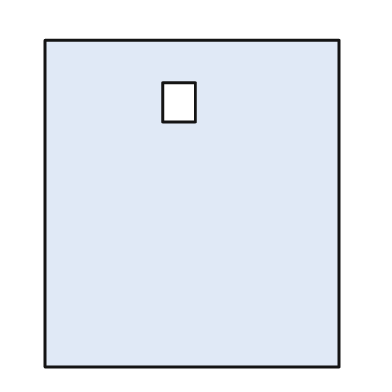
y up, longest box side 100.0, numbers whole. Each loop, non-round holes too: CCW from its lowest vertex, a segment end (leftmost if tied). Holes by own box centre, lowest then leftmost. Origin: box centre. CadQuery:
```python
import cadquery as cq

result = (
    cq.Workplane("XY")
    .moveTo(-45.0, -50.0)
    .lineTo(45.0, -50.0)
    .lineTo(45.0, 50.0)
    .lineTo(-45.0, 50.0)
    .close()
    .moveTo(-9.0, 25.0)
    .lineTo(1.0, 25.0)
    .lineTo(1.0, 37.0)
    .lineTo(-9.0, 37.0)
    .close()
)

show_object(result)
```